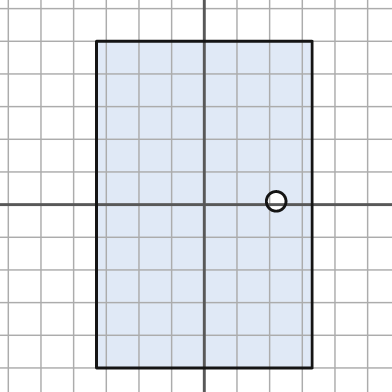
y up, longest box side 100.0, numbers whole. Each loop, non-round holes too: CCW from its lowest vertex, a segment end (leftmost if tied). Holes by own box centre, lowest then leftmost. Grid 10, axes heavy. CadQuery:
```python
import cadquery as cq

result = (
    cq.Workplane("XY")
    .moveTo(-33.0, -50.0)
    .lineTo(33.0, -50.0)
    .lineTo(33.0, 50.0)
    .lineTo(-33.0, 50.0)
    .close()
    .moveTo(22.0, 1.0)
    .circle(3.0)
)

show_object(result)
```